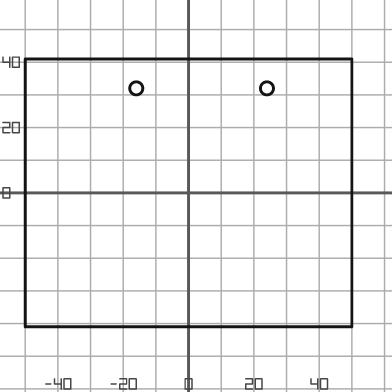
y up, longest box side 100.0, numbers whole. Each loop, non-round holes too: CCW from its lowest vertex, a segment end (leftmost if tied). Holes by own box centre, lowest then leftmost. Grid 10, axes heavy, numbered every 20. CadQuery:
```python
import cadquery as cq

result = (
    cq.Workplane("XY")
    .moveTo(-50.0, -41.0)
    .lineTo(50.0, -41.0)
    .lineTo(50.0, 41.0)
    .lineTo(-50.0, 41.0)
    .close()
    .moveTo(-16.0, 32.0)
    .circle(2.0)
    .moveTo(24.0, 32.0)
    .circle(2.0)
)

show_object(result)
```